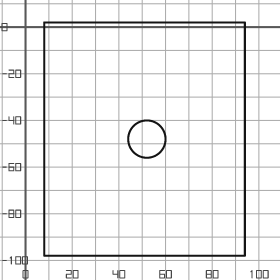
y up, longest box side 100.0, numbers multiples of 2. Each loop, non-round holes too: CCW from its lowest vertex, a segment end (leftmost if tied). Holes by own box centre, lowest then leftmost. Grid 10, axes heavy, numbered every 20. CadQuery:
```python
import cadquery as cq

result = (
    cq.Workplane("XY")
    .moveTo(8.0, -98.0)
    .lineTo(94.0, -98.0)
    .lineTo(94.0, 2.0)
    .lineTo(8.0, 2.0)
    .close()
    .moveTo(52.0, -48.0)
    .circle(8.0)
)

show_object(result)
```